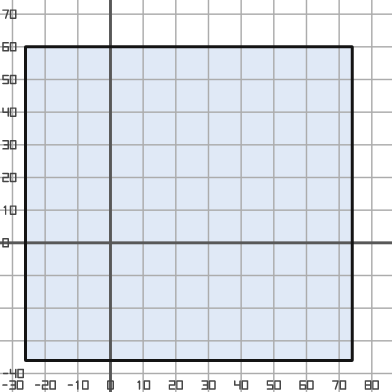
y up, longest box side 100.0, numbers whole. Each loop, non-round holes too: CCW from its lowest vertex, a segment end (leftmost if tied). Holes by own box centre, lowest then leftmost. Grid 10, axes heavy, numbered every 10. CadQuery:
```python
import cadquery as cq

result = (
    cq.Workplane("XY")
    .moveTo(-26.0, -36.0)
    .lineTo(74.0, -36.0)
    .lineTo(74.0, 60.0)
    .lineTo(-26.0, 60.0)
    .close()
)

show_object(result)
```